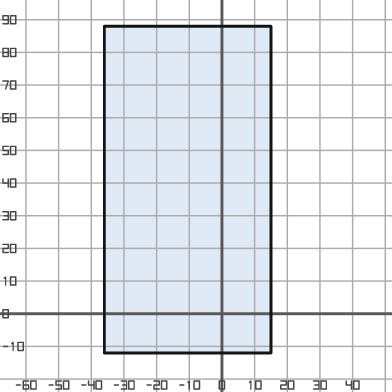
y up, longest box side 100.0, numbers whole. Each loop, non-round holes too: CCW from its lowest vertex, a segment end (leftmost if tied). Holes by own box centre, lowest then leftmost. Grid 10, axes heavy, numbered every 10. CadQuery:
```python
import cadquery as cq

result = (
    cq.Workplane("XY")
    .moveTo(-36.0, -12.0)
    .lineTo(15.0, -12.0)
    .lineTo(15.0, 88.0)
    .lineTo(-36.0, 88.0)
    .close()
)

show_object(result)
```